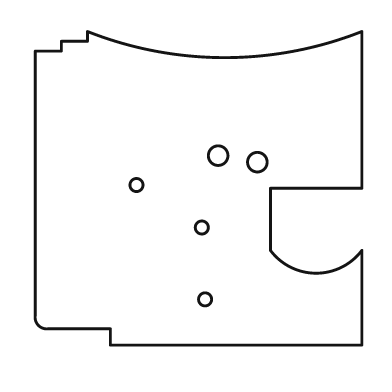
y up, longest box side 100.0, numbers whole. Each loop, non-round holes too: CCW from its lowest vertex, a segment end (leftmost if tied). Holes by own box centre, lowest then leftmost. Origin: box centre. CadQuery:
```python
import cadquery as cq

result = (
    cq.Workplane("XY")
    .moveTo(-27.0, -48.0)
    .lineTo(50.0, -48.0)
    .lineTo(50.0, -19.0)
    .threePointArc((36.0, -26.0), (22.0, -19.0))
    .lineTo(22.0, 0.0)
    .lineTo(50.0, 0.0)
    .lineTo(50.0, 48.0)
    .threePointArc((8.0, 40.0), (-34.0, 48.0))
    .lineTo(-34.0, 45.0)
    .lineTo(-42.0, 45.0)
    .lineTo(-42.0, 42.0)
    .lineTo(-50.0, 42.0)
    .lineTo(-50.0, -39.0)
    .threePointArc((-49.0, -42.0), (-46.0, -43.0))
    .lineTo(-27.0, -43.0)
    .close()
    .moveTo(2.0, -34.0)
    .circle(2.0)
    .moveTo(1.0, -12.0)
    .circle(2.0)
    .moveTo(-19.0, 1.0)
    .circle(2.0)
    .moveTo(18.0, 8.0)
    .circle(3.0)
    .moveTo(6.0, 10.0)
    .circle(3.0)
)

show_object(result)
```